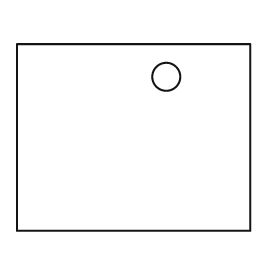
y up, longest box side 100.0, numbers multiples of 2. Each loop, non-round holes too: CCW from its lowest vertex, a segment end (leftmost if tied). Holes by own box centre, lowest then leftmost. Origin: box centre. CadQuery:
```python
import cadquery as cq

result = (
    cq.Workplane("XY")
    .moveTo(-50.0, -40.0)
    .lineTo(50.0, -40.0)
    .lineTo(50.0, 40.0)
    .lineTo(-50.0, 40.0)
    .close()
    .moveTo(14.0, 26.0)
    .circle(6.0)
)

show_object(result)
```